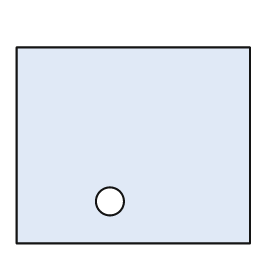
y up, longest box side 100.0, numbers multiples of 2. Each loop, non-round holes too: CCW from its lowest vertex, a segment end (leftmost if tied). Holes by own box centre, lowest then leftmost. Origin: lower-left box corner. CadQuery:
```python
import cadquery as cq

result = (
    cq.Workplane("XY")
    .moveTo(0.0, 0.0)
    .lineTo(100.0, 0.0)
    .lineTo(100.0, 84.0)
    .lineTo(0.0, 84.0)
    .close()
    .moveTo(40.0, 18.0)
    .circle(6.0)
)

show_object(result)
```